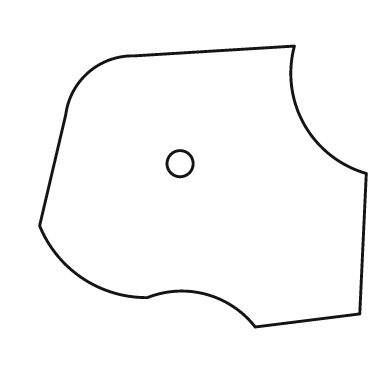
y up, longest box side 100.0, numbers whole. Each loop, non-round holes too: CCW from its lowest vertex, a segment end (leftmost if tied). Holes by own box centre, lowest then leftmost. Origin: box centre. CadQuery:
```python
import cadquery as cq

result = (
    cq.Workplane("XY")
    .moveTo(16.0, -43.0)
    .lineTo(48.0, -39.0)
    .lineTo(50.0, 4.0)
    .threePointArc((31.0, 19.0), (28.0, 43.0))
    .lineTo(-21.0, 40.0)
    .threePointArc((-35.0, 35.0), (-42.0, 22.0))
    .lineTo(-50.0, -12.0)
    .threePointArc((-37.0, -28.0), (-17.0, -34.0))
    .threePointArc((1.0, -33.0), (16.0, -43.0))
    .close()
    .moveTo(-7.0, 7.0)
    .circle(4.0)
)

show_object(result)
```